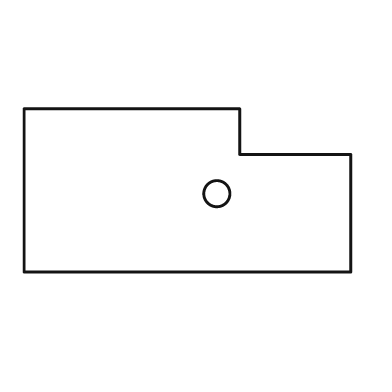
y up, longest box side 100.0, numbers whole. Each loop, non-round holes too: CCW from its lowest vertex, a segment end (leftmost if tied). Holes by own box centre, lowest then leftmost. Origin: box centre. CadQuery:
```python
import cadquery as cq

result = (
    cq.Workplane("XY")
    .moveTo(-50.0, -25.0)
    .lineTo(50.0, -25.0)
    .lineTo(50.0, 11.0)
    .lineTo(16.0, 11.0)
    .lineTo(16.0, 25.0)
    .lineTo(-50.0, 25.0)
    .close()
    .moveTo(9.0, -1.0)
    .circle(4.0)
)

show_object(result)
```